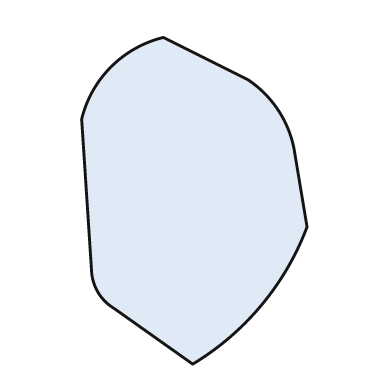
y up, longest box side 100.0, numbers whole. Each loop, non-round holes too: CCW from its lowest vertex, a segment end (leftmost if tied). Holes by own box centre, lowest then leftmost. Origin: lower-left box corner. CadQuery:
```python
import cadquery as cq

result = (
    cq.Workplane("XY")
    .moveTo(34.0, 0.0)
    .threePointArc((55.0, 18.0), (69.0, 42.0))
    .lineTo(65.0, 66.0)
    .threePointArc((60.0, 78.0), (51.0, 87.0))
    .lineTo(25.0, 100.0)
    .threePointArc((9.0, 91.0), (0.0, 75.0))
    .lineTo(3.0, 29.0)
    .threePointArc((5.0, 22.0), (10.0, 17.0))
    .close()
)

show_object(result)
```